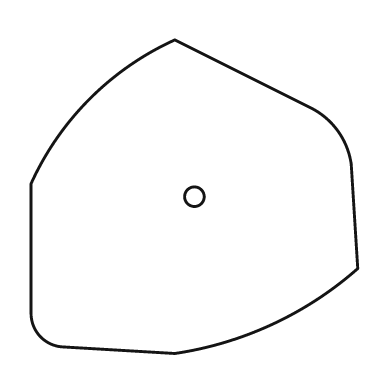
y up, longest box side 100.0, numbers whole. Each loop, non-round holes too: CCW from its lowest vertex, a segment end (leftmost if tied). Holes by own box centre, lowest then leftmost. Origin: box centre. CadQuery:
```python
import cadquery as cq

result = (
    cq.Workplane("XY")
    .moveTo(-6.0, -48.0)
    .threePointArc((24.0, -39.0), (50.0, -22.0))
    .lineTo(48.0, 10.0)
    .threePointArc((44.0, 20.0), (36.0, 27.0))
    .lineTo(-6.0, 48.0)
    .threePointArc((-32.0, 30.0), (-50.0, 4.0))
    .lineTo(-50.0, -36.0)
    .threePointArc((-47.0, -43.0), (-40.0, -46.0))
    .close()
    .moveTo(0.0, 0.0)
    .circle(3.0)
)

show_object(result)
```